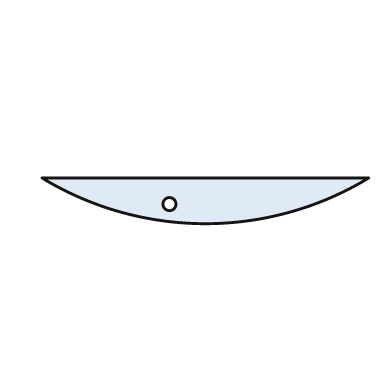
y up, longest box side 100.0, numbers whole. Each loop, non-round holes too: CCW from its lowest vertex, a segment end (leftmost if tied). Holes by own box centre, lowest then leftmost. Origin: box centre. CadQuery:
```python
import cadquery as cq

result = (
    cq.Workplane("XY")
    .moveTo(-50.0, 7.0)
    .threePointArc((0.0, -7.0), (50.0, 7.0))
    .close()
    .moveTo(-11.0, -1.0)
    .circle(2.0)
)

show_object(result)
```